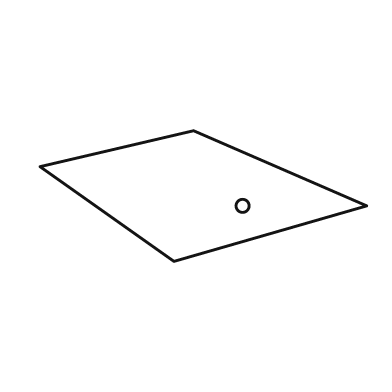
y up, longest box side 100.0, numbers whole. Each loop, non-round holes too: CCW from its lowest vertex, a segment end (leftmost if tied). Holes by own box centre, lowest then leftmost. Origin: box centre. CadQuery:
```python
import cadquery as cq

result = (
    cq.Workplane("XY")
    .moveTo(-9.0, -20.0)
    .lineTo(50.0, -3.0)
    .lineTo(-3.0, 20.0)
    .lineTo(-50.0, 9.0)
    .close()
    .moveTo(12.0, -3.0)
    .circle(2.0)
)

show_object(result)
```